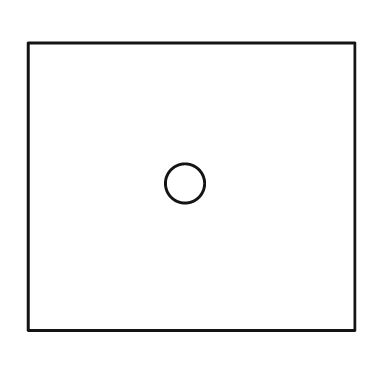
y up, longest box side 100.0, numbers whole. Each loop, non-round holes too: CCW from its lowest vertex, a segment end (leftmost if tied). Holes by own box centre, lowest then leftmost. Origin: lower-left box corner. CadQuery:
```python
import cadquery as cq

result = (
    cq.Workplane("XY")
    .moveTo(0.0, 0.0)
    .lineTo(100.0, 0.0)
    .lineTo(100.0, 88.0)
    .lineTo(0.0, 88.0)
    .close()
    .moveTo(48.0, 45.0)
    .circle(6.0)
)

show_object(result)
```